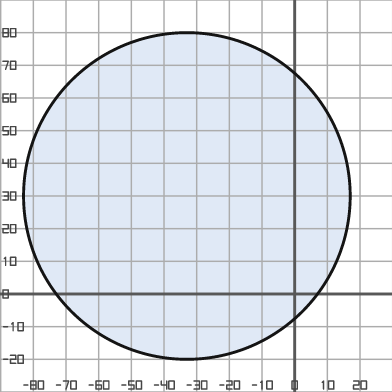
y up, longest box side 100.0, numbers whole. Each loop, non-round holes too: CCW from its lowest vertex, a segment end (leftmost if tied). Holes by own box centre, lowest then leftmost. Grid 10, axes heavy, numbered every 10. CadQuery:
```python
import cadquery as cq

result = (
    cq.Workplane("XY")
    .moveTo(-33.0, 30.0)
    .circle(50.0)
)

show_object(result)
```